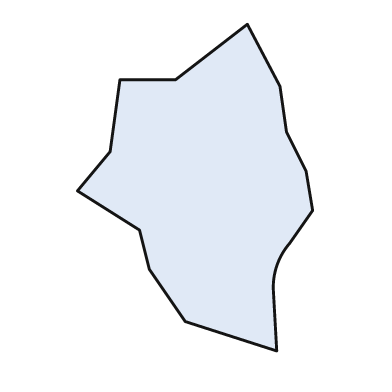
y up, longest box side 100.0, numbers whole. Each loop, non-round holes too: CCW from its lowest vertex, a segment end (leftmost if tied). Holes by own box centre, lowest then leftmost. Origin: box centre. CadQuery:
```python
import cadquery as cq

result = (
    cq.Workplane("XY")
    .moveTo(25.0, -50.0)
    .lineTo(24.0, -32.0)
    .threePointArc((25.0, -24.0), (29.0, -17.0))
    .lineTo(36.0, -7.0)
    .lineTo(34.0, 5.0)
    .lineTo(28.0, 17.0)
    .lineTo(26.0, 31.0)
    .lineTo(16.0, 50.0)
    .lineTo(-6.0, 33.0)
    .lineTo(-23.0, 33.0)
    .lineTo(-26.0, 11.0)
    .lineTo(-36.0, -1.0)
    .lineTo(-17.0, -13.0)
    .lineTo(-14.0, -25.0)
    .lineTo(-3.0, -41.0)
    .close()
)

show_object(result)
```